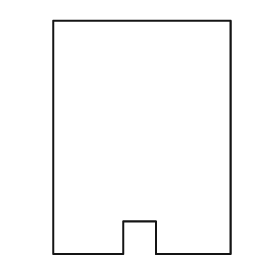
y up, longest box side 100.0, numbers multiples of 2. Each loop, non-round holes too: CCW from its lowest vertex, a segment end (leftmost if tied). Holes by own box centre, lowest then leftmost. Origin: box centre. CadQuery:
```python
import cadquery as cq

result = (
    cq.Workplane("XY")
    .moveTo(-38.0, -50.0)
    .lineTo(-8.0, -50.0)
    .lineTo(-8.0, -36.0)
    .lineTo(6.0, -36.0)
    .lineTo(6.0, -50.0)
    .lineTo(38.0, -50.0)
    .lineTo(38.0, 50.0)
    .lineTo(-38.0, 50.0)
    .close()
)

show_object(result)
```